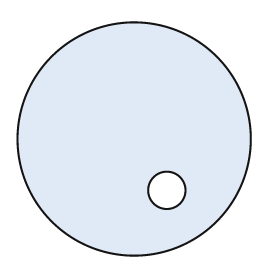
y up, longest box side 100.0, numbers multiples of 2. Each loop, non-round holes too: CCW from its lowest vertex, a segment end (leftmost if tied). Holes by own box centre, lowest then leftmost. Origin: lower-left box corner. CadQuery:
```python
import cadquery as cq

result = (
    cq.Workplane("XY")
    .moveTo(50.0, 50.0)
    .circle(50.0)
    .moveTo(64.0, 28.0)
    .circle(8.0)
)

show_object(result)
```